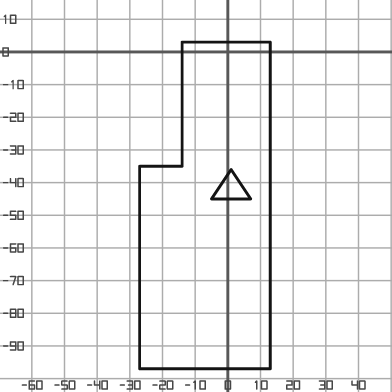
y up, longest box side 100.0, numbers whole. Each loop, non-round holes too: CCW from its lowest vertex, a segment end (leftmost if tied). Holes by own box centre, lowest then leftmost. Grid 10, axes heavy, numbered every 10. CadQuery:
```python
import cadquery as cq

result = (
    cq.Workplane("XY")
    .moveTo(-27.0, -97.0)
    .lineTo(13.0, -97.0)
    .lineTo(13.0, 3.0)
    .lineTo(-14.0, 3.0)
    .lineTo(-14.0, -35.0)
    .lineTo(-27.0, -35.0)
    .close()
    .moveTo(-5.0, -45.0)
    .lineTo(7.0, -45.0)
    .lineTo(1.0, -36.0)
    .close()
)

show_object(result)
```